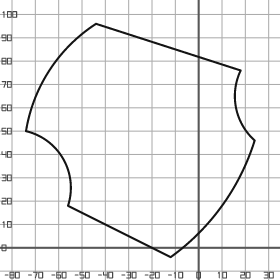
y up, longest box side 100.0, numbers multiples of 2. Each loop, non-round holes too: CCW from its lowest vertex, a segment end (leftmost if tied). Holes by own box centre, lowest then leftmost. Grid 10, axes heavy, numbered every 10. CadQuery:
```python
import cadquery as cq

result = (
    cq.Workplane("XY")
    .moveTo(-12.0, -4.0)
    .threePointArc((10.0, 18.0), (24.0, 46.0))
    .threePointArc((16.0, 60.0), (18.0, 76.0))
    .lineTo(-44.0, 96.0)
    .threePointArc((-64.0, 76.0), (-74.0, 50.0))
    .threePointArc((-58.0, 38.0), (-56.0, 18.0))
    .close()
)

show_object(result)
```